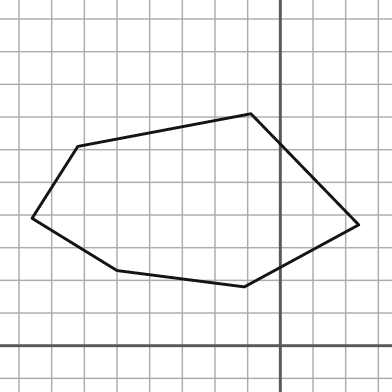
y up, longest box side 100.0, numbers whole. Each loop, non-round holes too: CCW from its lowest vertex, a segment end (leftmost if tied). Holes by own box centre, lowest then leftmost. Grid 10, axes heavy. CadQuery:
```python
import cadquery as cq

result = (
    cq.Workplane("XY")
    .moveTo(-11.0, 18.0)
    .lineTo(24.0, 37.0)
    .lineTo(-9.0, 71.0)
    .lineTo(-62.0, 61.0)
    .lineTo(-76.0, 39.0)
    .lineTo(-50.0, 23.0)
    .close()
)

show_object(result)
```